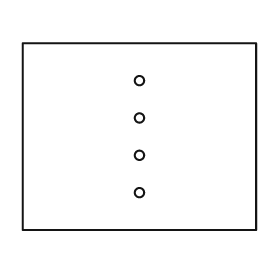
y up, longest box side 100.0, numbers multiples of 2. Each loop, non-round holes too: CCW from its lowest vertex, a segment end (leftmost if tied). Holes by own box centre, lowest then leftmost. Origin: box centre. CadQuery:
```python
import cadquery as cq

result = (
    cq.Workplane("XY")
    .moveTo(-50.0, -40.0)
    .lineTo(50.0, -40.0)
    .lineTo(50.0, 40.0)
    .lineTo(-50.0, 40.0)
    .close()
    .moveTo(0.0, -24.0)
    .circle(2.0)
    .moveTo(0.0, -8.0)
    .circle(2.0)
    .moveTo(0.0, 8.0)
    .circle(2.0)
    .moveTo(0.0, 24.0)
    .circle(2.0)
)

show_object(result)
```